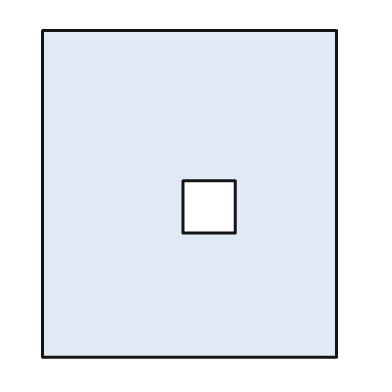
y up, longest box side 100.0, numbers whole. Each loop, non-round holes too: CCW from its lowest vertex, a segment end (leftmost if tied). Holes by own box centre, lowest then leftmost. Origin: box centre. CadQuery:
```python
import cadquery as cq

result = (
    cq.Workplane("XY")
    .moveTo(-45.0, -50.0)
    .lineTo(45.0, -50.0)
    .lineTo(45.0, 50.0)
    .lineTo(-45.0, 50.0)
    .close()
    .moveTo(-2.0, -12.0)
    .lineTo(14.0, -12.0)
    .lineTo(14.0, 4.0)
    .lineTo(-2.0, 4.0)
    .close()
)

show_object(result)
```